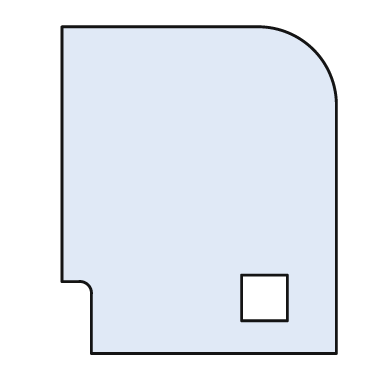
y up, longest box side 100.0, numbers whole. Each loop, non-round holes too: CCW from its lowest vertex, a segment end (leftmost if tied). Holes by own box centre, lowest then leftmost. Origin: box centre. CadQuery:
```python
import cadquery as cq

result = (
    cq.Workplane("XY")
    .moveTo(-33.0, -50.0)
    .lineTo(42.0, -50.0)
    .lineTo(42.0, 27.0)
    .threePointArc((35.0, 43.0), (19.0, 50.0))
    .lineTo(-42.0, 50.0)
    .lineTo(-42.0, -28.0)
    .lineTo(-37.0, -28.0)
    .threePointArc((-34.0, -29.0), (-33.0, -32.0))
    .close()
    .moveTo(13.0, -40.0)
    .lineTo(27.0, -40.0)
    .lineTo(27.0, -26.0)
    .lineTo(13.0, -26.0)
    .close()
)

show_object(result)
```